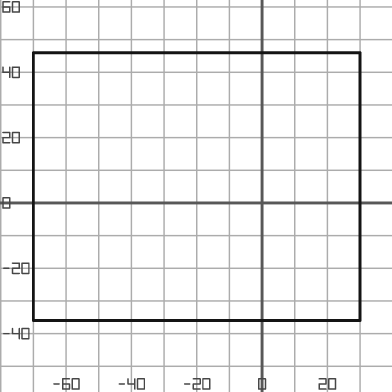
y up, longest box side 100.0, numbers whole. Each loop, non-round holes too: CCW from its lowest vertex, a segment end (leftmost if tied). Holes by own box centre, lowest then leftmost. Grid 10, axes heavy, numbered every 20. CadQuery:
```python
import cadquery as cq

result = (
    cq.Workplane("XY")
    .moveTo(-70.0, -36.0)
    .lineTo(30.0, -36.0)
    .lineTo(30.0, 46.0)
    .lineTo(-70.0, 46.0)
    .close()
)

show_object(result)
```